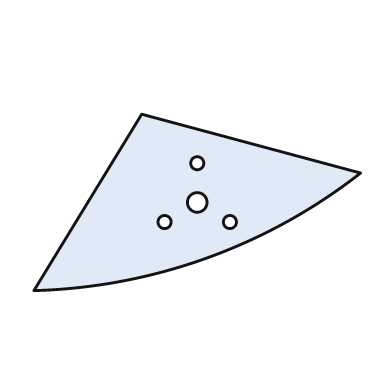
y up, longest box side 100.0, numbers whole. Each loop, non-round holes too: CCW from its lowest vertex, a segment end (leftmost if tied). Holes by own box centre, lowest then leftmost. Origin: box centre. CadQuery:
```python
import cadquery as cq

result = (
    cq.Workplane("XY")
    .moveTo(-50.0, -27.0)
    .threePointArc((3.0, -17.0), (50.0, 9.0))
    .lineTo(-17.0, 27.0)
    .close()
    .moveTo(-10.0, -6.0)
    .circle(2.0)
    .moveTo(10.0, -6.0)
    .circle(2.0)
    .moveTo(0.0, 0.0)
    .circle(3.0)
    .moveTo(0.0, 12.0)
    .circle(2.0)
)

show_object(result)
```